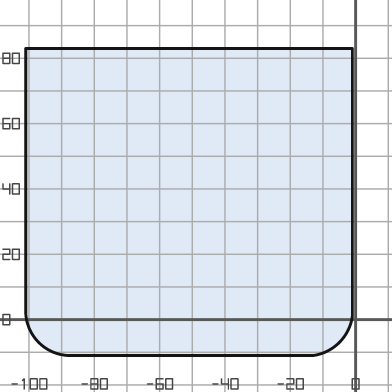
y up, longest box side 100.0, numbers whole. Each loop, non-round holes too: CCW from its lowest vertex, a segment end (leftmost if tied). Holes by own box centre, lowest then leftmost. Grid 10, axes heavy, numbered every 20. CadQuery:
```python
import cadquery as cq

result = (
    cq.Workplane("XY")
    .moveTo(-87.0, -11.0)
    .lineTo(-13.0, -11.0)
    .threePointArc((-5.0, -7.0), (-1.0, 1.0))
    .lineTo(-1.0, 83.0)
    .lineTo(-101.0, 83.0)
    .lineTo(-101.0, 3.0)
    .threePointArc((-97.0, -7.0), (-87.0, -11.0))
    .close()
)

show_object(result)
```